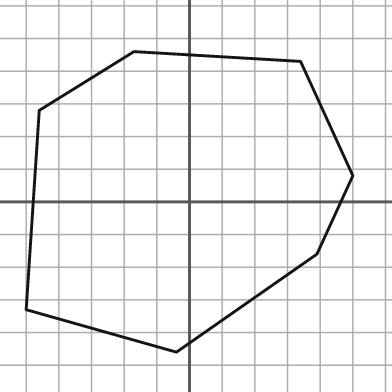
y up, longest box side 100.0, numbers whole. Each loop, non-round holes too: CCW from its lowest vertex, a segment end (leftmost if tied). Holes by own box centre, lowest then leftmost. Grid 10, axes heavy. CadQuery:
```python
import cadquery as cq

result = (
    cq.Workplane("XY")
    .moveTo(-4.0, -46.0)
    .lineTo(39.0, -16.0)
    .lineTo(50.0, 8.0)
    .lineTo(34.0, 43.0)
    .lineTo(-17.0, 46.0)
    .lineTo(-46.0, 28.0)
    .lineTo(-50.0, -33.0)
    .close()
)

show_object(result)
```